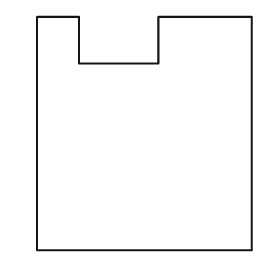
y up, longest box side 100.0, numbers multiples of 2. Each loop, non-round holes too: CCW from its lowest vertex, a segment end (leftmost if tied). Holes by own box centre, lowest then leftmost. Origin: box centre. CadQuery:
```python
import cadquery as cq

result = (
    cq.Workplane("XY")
    .moveTo(-46.0, -50.0)
    .lineTo(46.0, -50.0)
    .lineTo(46.0, 50.0)
    .lineTo(6.0, 50.0)
    .lineTo(6.0, 30.0)
    .lineTo(-28.0, 30.0)
    .lineTo(-28.0, 50.0)
    .lineTo(-46.0, 50.0)
    .close()
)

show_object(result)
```